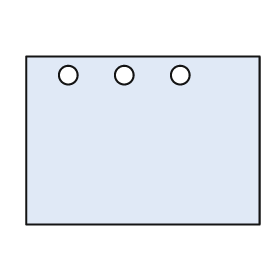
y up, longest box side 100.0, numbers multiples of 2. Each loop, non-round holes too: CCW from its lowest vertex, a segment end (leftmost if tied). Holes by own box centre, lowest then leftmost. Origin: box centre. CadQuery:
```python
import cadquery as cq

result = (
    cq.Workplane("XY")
    .moveTo(-50.0, -36.0)
    .lineTo(50.0, -36.0)
    .lineTo(50.0, 36.0)
    .lineTo(-50.0, 36.0)
    .close()
    .moveTo(-32.0, 28.0)
    .circle(4.0)
    .moveTo(-8.0, 28.0)
    .circle(4.0)
    .moveTo(16.0, 28.0)
    .circle(4.0)
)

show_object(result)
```